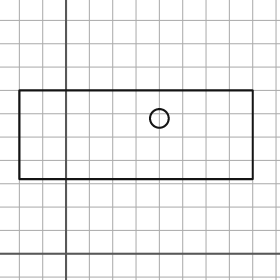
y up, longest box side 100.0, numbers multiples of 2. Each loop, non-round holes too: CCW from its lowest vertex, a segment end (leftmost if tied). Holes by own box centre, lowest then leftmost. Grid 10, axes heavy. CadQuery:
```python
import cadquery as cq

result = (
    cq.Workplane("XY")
    .moveTo(-20.0, 32.0)
    .lineTo(80.0, 32.0)
    .lineTo(80.0, 70.0)
    .lineTo(-20.0, 70.0)
    .close()
    .moveTo(40.0, 58.0)
    .circle(4.0)
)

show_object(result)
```